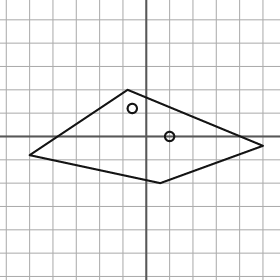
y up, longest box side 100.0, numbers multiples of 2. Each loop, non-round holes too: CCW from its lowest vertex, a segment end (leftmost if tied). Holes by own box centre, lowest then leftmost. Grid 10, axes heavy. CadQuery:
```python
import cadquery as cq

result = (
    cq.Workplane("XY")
    .moveTo(6.0, -20.0)
    .lineTo(50.0, -4.0)
    .lineTo(-8.0, 20.0)
    .lineTo(-50.0, -8.0)
    .close()
    .moveTo(10.0, 0.0)
    .circle(2.0)
    .moveTo(-6.0, 12.0)
    .circle(2.0)
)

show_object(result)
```